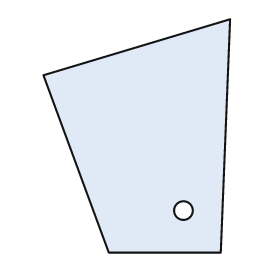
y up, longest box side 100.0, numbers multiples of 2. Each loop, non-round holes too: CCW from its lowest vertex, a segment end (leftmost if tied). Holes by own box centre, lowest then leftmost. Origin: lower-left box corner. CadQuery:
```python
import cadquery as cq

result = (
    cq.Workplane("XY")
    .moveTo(28.0, 0.0)
    .lineTo(76.0, 0.0)
    .lineTo(80.0, 100.0)
    .lineTo(0.0, 76.0)
    .close()
    .moveTo(60.0, 18.0)
    .circle(4.0)
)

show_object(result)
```